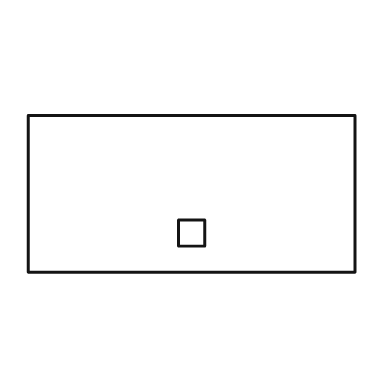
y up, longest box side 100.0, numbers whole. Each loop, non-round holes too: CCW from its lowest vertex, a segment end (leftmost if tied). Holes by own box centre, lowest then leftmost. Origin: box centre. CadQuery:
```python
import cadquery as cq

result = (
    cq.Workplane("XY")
    .moveTo(-50.0, -24.0)
    .lineTo(50.0, -24.0)
    .lineTo(50.0, 24.0)
    .lineTo(-50.0, 24.0)
    .close()
    .moveTo(-4.0, -16.0)
    .lineTo(4.0, -16.0)
    .lineTo(4.0, -8.0)
    .lineTo(-4.0, -8.0)
    .close()
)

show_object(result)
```